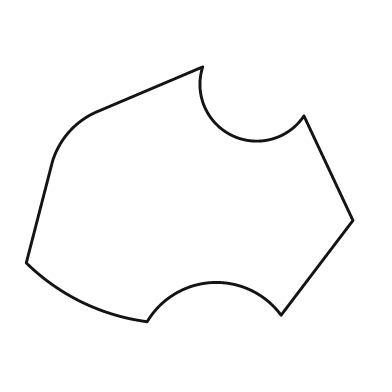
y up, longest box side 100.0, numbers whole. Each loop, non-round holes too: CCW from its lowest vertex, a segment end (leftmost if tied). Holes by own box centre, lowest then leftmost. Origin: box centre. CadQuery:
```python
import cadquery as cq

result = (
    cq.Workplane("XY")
    .moveTo(-13.0, -39.0)
    .threePointArc((7.0, -27.0), (28.0, -37.0))
    .lineTo(50.0, -8.0)
    .lineTo(35.0, 24.0)
    .threePointArc((13.0, 18.0), (4.0, 39.0))
    .lineTo(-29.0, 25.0)
    .threePointArc((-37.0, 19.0), (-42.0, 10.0))
    .lineTo(-50.0, -21.0)
    .threePointArc((-33.0, -33.0), (-13.0, -39.0))
    .close()
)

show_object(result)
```